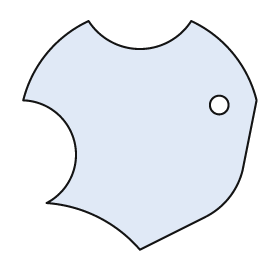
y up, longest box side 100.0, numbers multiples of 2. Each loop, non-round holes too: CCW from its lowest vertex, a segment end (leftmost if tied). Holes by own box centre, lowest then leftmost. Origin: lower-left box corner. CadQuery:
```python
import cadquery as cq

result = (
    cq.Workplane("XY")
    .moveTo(50.0, 0.0)
    .lineTo(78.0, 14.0)
    .threePointArc((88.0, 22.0), (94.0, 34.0))
    .lineTo(100.0, 64.0)
    .threePointArc((90.0, 84.0), (72.0, 98.0))
    .threePointArc((50.0, 86.0), (28.0, 98.0))
    .threePointArc((10.0, 84.0), (0.0, 64.0))
    .threePointArc((22.0, 46.0), (10.0, 20.0))
    .threePointArc((32.0, 14.0), (50.0, 0.0))
    .close()
    .moveTo(84.0, 62.0)
    .circle(4.0)
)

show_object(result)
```